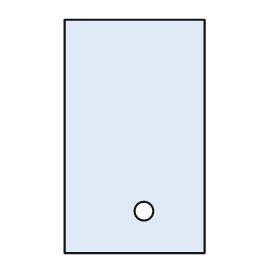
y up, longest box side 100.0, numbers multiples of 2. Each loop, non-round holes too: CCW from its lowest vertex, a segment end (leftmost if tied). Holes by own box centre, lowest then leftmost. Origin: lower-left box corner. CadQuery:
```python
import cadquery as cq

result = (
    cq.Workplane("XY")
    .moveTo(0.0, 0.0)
    .lineTo(60.0, 0.0)
    .lineTo(60.0, 100.0)
    .lineTo(0.0, 100.0)
    .close()
    .moveTo(34.0, 18.0)
    .circle(4.0)
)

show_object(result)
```